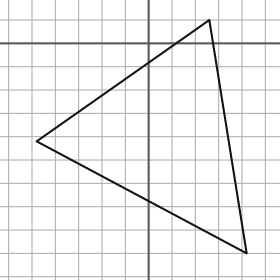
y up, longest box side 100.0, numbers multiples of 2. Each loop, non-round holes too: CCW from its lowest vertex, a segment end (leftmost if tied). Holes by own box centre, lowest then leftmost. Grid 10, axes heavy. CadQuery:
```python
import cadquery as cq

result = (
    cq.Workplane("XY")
    .moveTo(42.0, -90.0)
    .lineTo(26.0, 10.0)
    .lineTo(-48.0, -42.0)
    .close()
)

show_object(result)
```